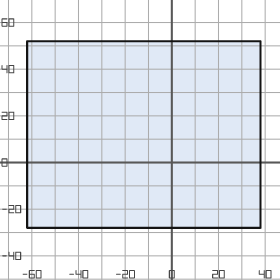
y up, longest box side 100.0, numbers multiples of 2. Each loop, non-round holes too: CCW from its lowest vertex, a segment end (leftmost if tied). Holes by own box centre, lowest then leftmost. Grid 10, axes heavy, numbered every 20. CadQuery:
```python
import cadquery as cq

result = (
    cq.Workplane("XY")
    .moveTo(-62.0, -28.0)
    .lineTo(38.0, -28.0)
    .lineTo(38.0, 52.0)
    .lineTo(-62.0, 52.0)
    .close()
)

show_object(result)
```